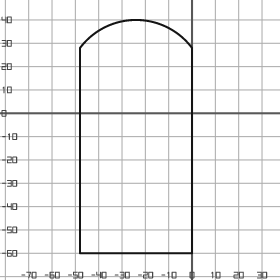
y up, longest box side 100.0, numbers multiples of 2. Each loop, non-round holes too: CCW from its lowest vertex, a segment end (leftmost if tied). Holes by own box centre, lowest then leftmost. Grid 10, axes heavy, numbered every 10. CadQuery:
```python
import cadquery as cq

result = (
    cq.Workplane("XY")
    .moveTo(-48.0, -60.0)
    .lineTo(0.0, -60.0)
    .lineTo(0.0, 28.0)
    .threePointArc((-24.0, 40.0), (-48.0, 28.0))
    .close()
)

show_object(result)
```